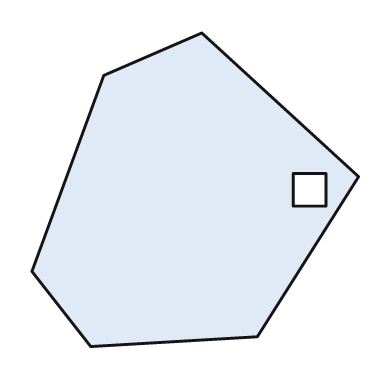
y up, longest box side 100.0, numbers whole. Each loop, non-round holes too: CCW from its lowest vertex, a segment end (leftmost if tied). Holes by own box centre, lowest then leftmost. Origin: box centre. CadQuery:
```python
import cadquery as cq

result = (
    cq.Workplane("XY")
    .moveTo(-32.0, -48.0)
    .lineTo(19.0, -45.0)
    .lineTo(50.0, 4.0)
    .lineTo(2.0, 48.0)
    .lineTo(-28.0, 35.0)
    .lineTo(-50.0, -25.0)
    .close()
    .moveTo(30.0, -5.0)
    .lineTo(40.0, -5.0)
    .lineTo(40.0, 5.0)
    .lineTo(30.0, 5.0)
    .close()
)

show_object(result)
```